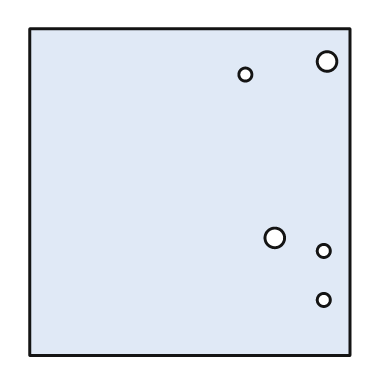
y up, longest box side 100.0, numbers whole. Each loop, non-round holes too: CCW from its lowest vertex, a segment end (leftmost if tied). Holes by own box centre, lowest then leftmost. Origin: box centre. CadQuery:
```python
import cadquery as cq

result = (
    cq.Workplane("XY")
    .moveTo(-49.0, -50.0)
    .lineTo(49.0, -50.0)
    .lineTo(49.0, 50.0)
    .lineTo(-49.0, 50.0)
    .close()
    .moveTo(41.0, -33.0)
    .circle(2.0)
    .moveTo(41.0, -18.0)
    .circle(2.0)
    .moveTo(26.0, -14.0)
    .circle(3.0)
    .moveTo(17.0, 36.0)
    .circle(2.0)
    .moveTo(42.0, 40.0)
    .circle(3.0)
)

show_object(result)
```